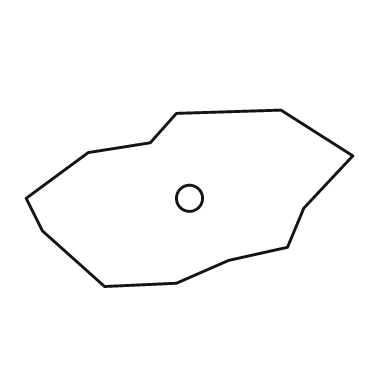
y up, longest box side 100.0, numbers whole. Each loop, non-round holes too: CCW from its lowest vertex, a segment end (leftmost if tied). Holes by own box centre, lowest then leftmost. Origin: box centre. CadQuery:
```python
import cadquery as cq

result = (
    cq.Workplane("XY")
    .moveTo(-26.0, -27.0)
    .lineTo(-4.0, -26.0)
    .lineTo(12.0, -19.0)
    .lineTo(30.0, -15.0)
    .lineTo(35.0, -3.0)
    .lineTo(50.0, 13.0)
    .lineTo(28.0, 27.0)
    .lineTo(-4.0, 26.0)
    .lineTo(-12.0, 17.0)
    .lineTo(-31.0, 14.0)
    .lineTo(-50.0, 0.0)
    .lineTo(-45.0, -10.0)
    .close()
    .moveTo(0.0, 0.0)
    .circle(4.0)
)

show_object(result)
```